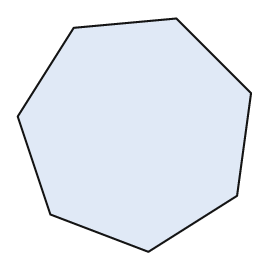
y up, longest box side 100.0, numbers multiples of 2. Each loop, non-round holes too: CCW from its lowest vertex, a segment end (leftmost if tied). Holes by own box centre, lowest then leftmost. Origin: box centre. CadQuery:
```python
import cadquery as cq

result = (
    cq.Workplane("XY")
    .moveTo(6.0, -50.0)
    .lineTo(44.0, -26.0)
    .lineTo(50.0, 18.0)
    .lineTo(18.0, 50.0)
    .lineTo(-26.0, 46.0)
    .lineTo(-50.0, 8.0)
    .lineTo(-36.0, -34.0)
    .close()
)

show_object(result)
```